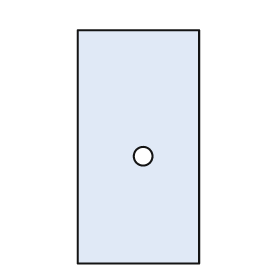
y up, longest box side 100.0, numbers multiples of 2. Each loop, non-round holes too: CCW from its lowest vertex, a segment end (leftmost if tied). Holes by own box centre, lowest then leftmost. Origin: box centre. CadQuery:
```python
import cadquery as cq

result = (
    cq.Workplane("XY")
    .moveTo(-26.0, -50.0)
    .lineTo(26.0, -50.0)
    .lineTo(26.0, 50.0)
    .lineTo(-26.0, 50.0)
    .close()
    .moveTo(2.0, -4.0)
    .circle(4.0)
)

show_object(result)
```